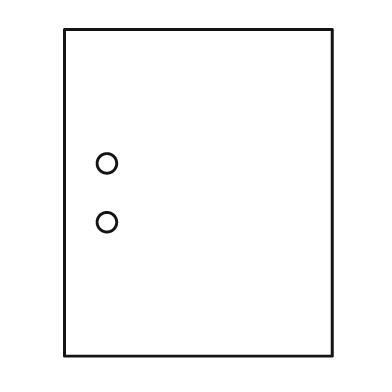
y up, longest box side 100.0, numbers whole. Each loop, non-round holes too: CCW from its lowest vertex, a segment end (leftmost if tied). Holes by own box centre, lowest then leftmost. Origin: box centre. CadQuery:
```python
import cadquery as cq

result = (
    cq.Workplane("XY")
    .moveTo(-41.0, -50.0)
    .lineTo(41.0, -50.0)
    .lineTo(41.0, 50.0)
    .lineTo(-41.0, 50.0)
    .close()
    .moveTo(-28.0, -9.0)
    .circle(3.0)
    .moveTo(-28.0, 9.0)
    .circle(3.0)
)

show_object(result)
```